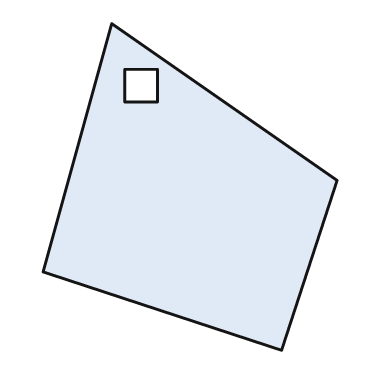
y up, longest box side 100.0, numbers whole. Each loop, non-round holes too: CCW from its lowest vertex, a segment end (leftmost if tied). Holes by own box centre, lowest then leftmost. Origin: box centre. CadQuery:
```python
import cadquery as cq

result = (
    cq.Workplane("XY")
    .moveTo(28.0, -50.0)
    .lineTo(45.0, 2.0)
    .lineTo(-24.0, 50.0)
    .lineTo(-45.0, -26.0)
    .close()
    .moveTo(-20.0, 26.0)
    .lineTo(-10.0, 26.0)
    .lineTo(-10.0, 36.0)
    .lineTo(-20.0, 36.0)
    .close()
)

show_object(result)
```